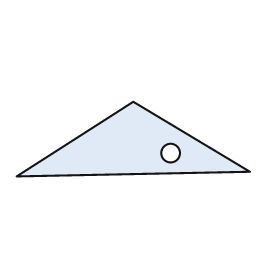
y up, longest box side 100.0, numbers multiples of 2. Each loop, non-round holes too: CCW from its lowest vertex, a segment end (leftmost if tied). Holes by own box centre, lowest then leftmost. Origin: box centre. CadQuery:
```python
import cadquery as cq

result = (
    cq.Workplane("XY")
    .moveTo(-50.0, -16.0)
    .lineTo(50.0, -14.0)
    .lineTo(0.0, 16.0)
    .close()
    .moveTo(16.0, -6.0)
    .circle(4.0)
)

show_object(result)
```